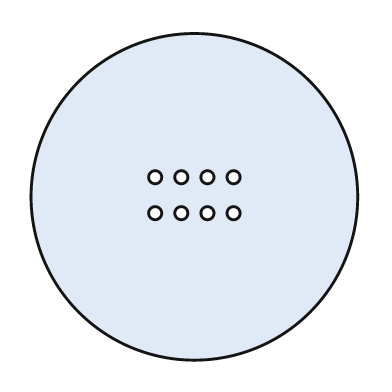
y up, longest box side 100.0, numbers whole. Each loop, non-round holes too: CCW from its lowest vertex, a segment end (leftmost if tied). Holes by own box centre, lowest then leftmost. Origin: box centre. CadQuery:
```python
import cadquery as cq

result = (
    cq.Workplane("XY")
    .moveTo(0.0, 0.0)
    .circle(50.0)
    .moveTo(-12.0, -5.0)
    .circle(2.0)
    .moveTo(-4.0, -5.0)
    .circle(2.0)
    .moveTo(4.0, -5.0)
    .circle(2.0)
    .moveTo(12.0, -5.0)
    .circle(2.0)
    .moveTo(-12.0, 6.0)
    .circle(2.0)
    .moveTo(-4.0, 6.0)
    .circle(2.0)
    .moveTo(4.0, 6.0)
    .circle(2.0)
    .moveTo(12.0, 6.0)
    .circle(2.0)
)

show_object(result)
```